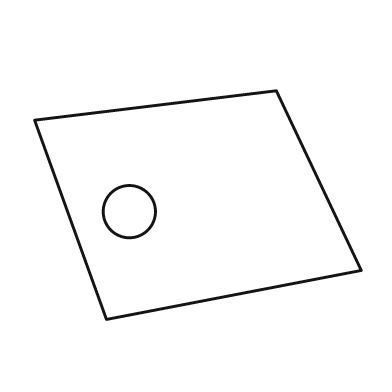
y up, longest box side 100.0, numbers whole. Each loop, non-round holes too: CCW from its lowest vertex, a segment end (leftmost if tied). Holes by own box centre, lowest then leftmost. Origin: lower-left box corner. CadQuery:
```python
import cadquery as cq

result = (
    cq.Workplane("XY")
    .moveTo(22.0, 0.0)
    .lineTo(100.0, 15.0)
    .lineTo(74.0, 70.0)
    .lineTo(0.0, 61.0)
    .close()
    .moveTo(29.0, 33.0)
    .circle(8.0)
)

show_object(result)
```